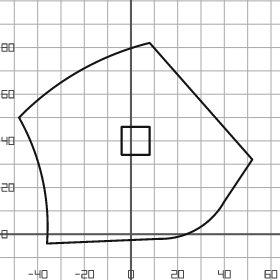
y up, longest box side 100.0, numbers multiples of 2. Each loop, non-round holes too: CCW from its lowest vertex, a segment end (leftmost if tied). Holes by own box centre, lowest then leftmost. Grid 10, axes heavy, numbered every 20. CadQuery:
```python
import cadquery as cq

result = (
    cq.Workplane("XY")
    .moveTo(-36.0, -4.0)
    .lineTo(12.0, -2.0)
    .threePointArc((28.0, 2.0), (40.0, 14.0))
    .lineTo(52.0, 32.0)
    .lineTo(8.0, 82.0)
    .threePointArc((-22.0, 70.0), (-48.0, 50.0))
    .threePointArc((-38.0, 24.0), (-36.0, -4.0))
    .close()
    .moveTo(-4.0, 34.0)
    .lineTo(8.0, 34.0)
    .lineTo(8.0, 46.0)
    .lineTo(-4.0, 46.0)
    .close()
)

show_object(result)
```